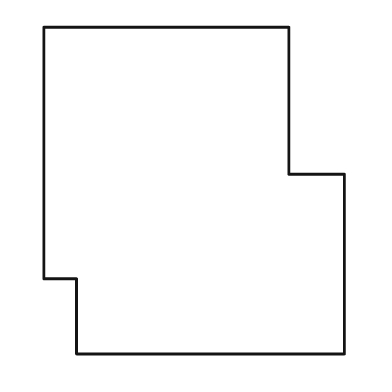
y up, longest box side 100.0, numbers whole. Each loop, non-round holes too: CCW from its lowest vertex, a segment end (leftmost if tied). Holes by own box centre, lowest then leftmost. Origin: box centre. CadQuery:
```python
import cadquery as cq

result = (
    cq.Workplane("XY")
    .moveTo(-36.0, -50.0)
    .lineTo(46.0, -50.0)
    .lineTo(46.0, 5.0)
    .lineTo(29.0, 5.0)
    .lineTo(29.0, 50.0)
    .lineTo(-46.0, 50.0)
    .lineTo(-46.0, -27.0)
    .lineTo(-36.0, -27.0)
    .close()
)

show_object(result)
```